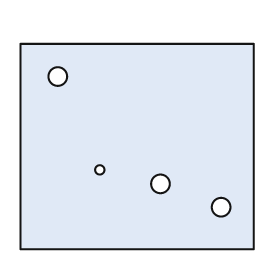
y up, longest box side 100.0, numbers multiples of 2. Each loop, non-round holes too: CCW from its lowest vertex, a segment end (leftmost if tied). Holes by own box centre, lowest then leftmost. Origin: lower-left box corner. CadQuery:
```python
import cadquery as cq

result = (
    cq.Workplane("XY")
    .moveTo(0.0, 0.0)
    .lineTo(100.0, 0.0)
    .lineTo(100.0, 88.0)
    .lineTo(0.0, 88.0)
    .close()
    .moveTo(86.0, 18.0)
    .circle(4.0)
    .moveTo(60.0, 28.0)
    .circle(4.0)
    .moveTo(34.0, 34.0)
    .circle(2.0)
    .moveTo(16.0, 74.0)
    .circle(4.0)
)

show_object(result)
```